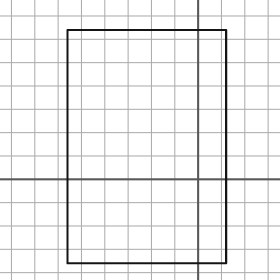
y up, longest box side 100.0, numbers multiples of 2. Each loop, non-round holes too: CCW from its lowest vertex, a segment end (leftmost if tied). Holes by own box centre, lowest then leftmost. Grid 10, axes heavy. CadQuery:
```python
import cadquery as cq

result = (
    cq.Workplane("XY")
    .moveTo(-56.0, -36.0)
    .lineTo(12.0, -36.0)
    .lineTo(12.0, 64.0)
    .lineTo(-56.0, 64.0)
    .close()
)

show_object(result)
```